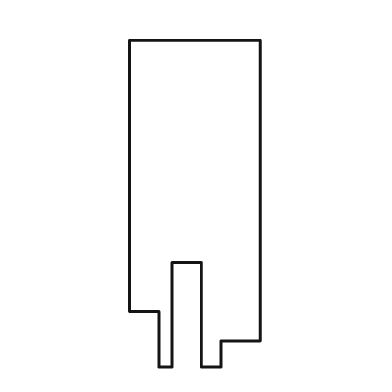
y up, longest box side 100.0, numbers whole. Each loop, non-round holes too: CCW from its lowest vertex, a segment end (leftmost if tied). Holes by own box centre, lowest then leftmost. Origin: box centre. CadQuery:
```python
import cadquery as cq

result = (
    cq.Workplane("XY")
    .moveTo(-11.0, -50.0)
    .lineTo(-7.0, -50.0)
    .lineTo(-7.0, -18.0)
    .lineTo(2.0, -18.0)
    .lineTo(2.0, -50.0)
    .lineTo(8.0, -50.0)
    .lineTo(8.0, -42.0)
    .lineTo(20.0, -42.0)
    .lineTo(20.0, 50.0)
    .lineTo(-20.0, 50.0)
    .lineTo(-20.0, -33.0)
    .lineTo(-11.0, -33.0)
    .close()
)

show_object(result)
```